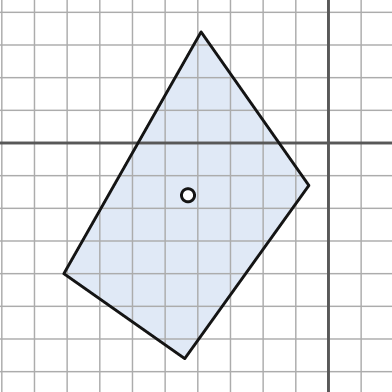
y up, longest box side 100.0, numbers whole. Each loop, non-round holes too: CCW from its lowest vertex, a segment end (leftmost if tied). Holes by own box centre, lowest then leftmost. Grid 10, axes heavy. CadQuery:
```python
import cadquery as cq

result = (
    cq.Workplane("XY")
    .moveTo(-44.0, -66.0)
    .lineTo(-6.0, -13.0)
    .lineTo(-39.0, 34.0)
    .lineTo(-81.0, -40.0)
    .close()
    .moveTo(-43.0, -16.0)
    .circle(2.0)
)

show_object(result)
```